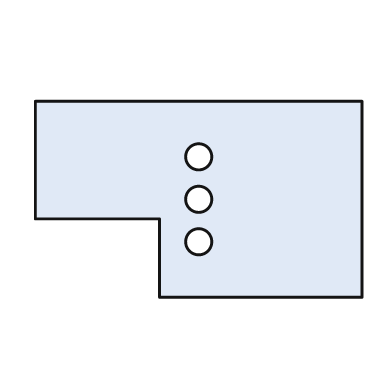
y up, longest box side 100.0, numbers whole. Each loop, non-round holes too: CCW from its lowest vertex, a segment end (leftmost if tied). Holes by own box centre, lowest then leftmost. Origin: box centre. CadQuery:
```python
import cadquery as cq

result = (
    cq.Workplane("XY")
    .moveTo(-12.0, -30.0)
    .lineTo(50.0, -30.0)
    .lineTo(50.0, 30.0)
    .lineTo(-50.0, 30.0)
    .lineTo(-50.0, -6.0)
    .lineTo(-12.0, -6.0)
    .close()
    .moveTo(0.0, -13.0)
    .circle(4.0)
    .moveTo(0.0, 0.0)
    .circle(4.0)
    .moveTo(0.0, 13.0)
    .circle(4.0)
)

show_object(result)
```